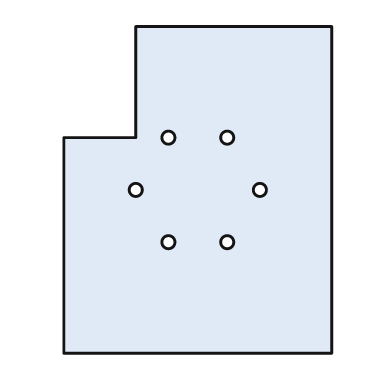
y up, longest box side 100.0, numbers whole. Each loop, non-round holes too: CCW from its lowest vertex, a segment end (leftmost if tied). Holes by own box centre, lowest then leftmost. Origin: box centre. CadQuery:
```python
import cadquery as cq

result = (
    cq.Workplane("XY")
    .moveTo(-41.0, -50.0)
    .lineTo(41.0, -50.0)
    .lineTo(41.0, 50.0)
    .lineTo(-19.0, 50.0)
    .lineTo(-19.0, 16.0)
    .lineTo(-41.0, 16.0)
    .close()
    .moveTo(-9.0, -16.0)
    .circle(2.0)
    .moveTo(9.0, -16.0)
    .circle(2.0)
    .moveTo(-19.0, 0.0)
    .circle(2.0)
    .moveTo(19.0, 0.0)
    .circle(2.0)
    .moveTo(-9.0, 16.0)
    .circle(2.0)
    .moveTo(9.0, 16.0)
    .circle(2.0)
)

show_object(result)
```